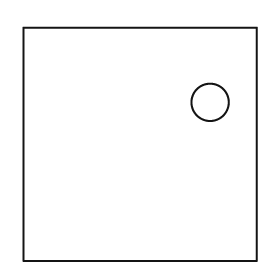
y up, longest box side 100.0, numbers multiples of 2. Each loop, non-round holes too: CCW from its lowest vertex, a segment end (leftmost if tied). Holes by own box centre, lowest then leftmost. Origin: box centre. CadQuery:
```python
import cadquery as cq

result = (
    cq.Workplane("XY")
    .moveTo(-50.0, -50.0)
    .lineTo(50.0, -50.0)
    .lineTo(50.0, 50.0)
    .lineTo(-50.0, 50.0)
    .close()
    .moveTo(30.0, 18.0)
    .circle(8.0)
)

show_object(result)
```